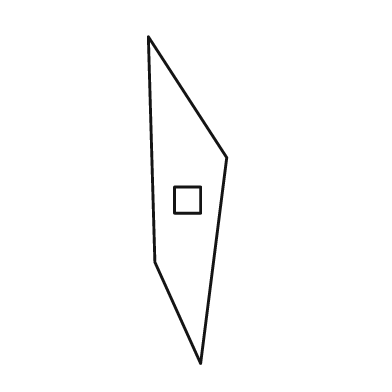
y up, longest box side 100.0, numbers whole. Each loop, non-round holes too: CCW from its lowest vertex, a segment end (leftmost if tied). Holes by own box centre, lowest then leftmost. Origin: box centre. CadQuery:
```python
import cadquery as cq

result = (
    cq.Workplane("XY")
    .moveTo(4.0, -50.0)
    .lineTo(12.0, 13.0)
    .lineTo(-12.0, 50.0)
    .lineTo(-10.0, -19.0)
    .close()
    .moveTo(-4.0, -4.0)
    .lineTo(4.0, -4.0)
    .lineTo(4.0, 4.0)
    .lineTo(-4.0, 4.0)
    .close()
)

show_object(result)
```